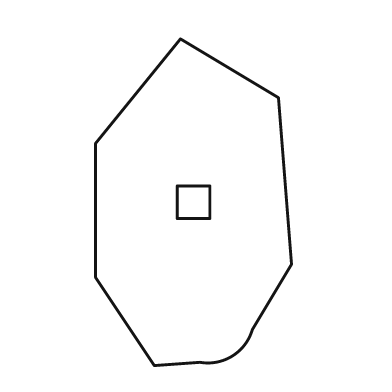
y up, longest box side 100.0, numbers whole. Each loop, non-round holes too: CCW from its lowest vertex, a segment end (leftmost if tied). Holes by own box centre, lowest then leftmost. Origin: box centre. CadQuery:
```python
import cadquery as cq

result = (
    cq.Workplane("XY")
    .moveTo(-12.0, -50.0)
    .lineTo(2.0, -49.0)
    .threePointArc((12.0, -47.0), (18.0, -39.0))
    .lineTo(30.0, -19.0)
    .lineTo(26.0, 32.0)
    .lineTo(-4.0, 50.0)
    .lineTo(-30.0, 18.0)
    .lineTo(-30.0, -23.0)
    .close()
    .moveTo(-5.0, -5.0)
    .lineTo(5.0, -5.0)
    .lineTo(5.0, 5.0)
    .lineTo(-5.0, 5.0)
    .close()
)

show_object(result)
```